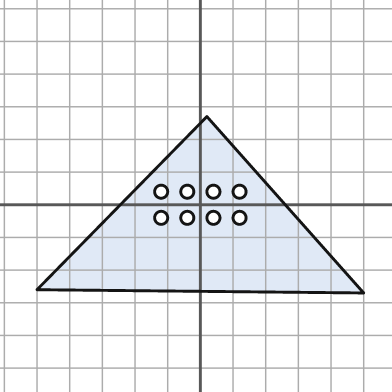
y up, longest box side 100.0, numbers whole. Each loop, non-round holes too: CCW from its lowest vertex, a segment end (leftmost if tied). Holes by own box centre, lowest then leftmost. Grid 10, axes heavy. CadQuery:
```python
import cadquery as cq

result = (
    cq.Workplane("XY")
    .moveTo(50.0, -27.0)
    .lineTo(2.0, 27.0)
    .lineTo(-50.0, -26.0)
    .close()
    .moveTo(-12.0, -4.0)
    .circle(2.0)
    .moveTo(-4.0, -4.0)
    .circle(2.0)
    .moveTo(4.0, -4.0)
    .circle(2.0)
    .moveTo(12.0, -4.0)
    .circle(2.0)
    .moveTo(-12.0, 4.0)
    .circle(2.0)
    .moveTo(-4.0, 4.0)
    .circle(2.0)
    .moveTo(4.0, 4.0)
    .circle(2.0)
    .moveTo(12.0, 4.0)
    .circle(2.0)
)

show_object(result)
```